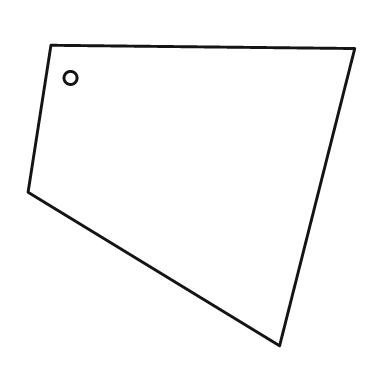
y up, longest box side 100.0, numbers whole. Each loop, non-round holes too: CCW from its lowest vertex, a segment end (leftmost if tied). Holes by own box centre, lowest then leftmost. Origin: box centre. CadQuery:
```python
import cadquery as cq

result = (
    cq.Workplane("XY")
    .moveTo(27.0, -46.0)
    .lineTo(50.0, 45.0)
    .lineTo(-43.0, 46.0)
    .lineTo(-50.0, 1.0)
    .close()
    .moveTo(-37.0, 36.0)
    .circle(2.0)
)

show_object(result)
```